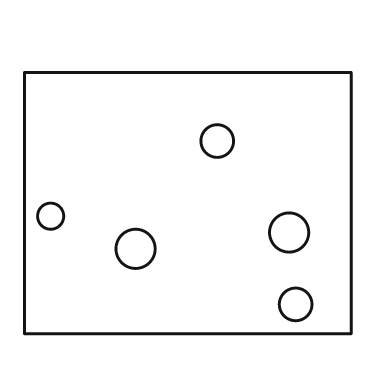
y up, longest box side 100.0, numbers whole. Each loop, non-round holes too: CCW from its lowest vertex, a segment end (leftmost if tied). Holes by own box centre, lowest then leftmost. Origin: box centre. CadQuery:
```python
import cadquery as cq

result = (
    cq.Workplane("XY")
    .moveTo(-50.0, -40.0)
    .lineTo(50.0, -40.0)
    .lineTo(50.0, 40.0)
    .lineTo(-50.0, 40.0)
    .close()
    .moveTo(33.0, -31.0)
    .circle(5.0)
    .moveTo(-16.0, -14.0)
    .circle(6.0)
    .moveTo(31.0, -9.0)
    .circle(6.0)
    .moveTo(-42.0, -4.0)
    .circle(4.0)
    .moveTo(9.0, 19.0)
    .circle(5.0)
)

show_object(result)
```